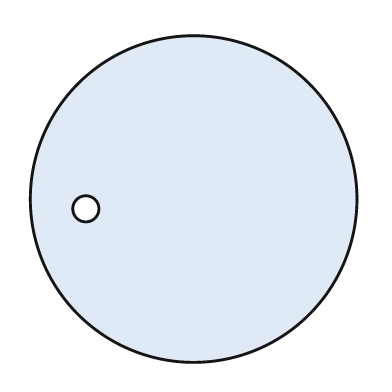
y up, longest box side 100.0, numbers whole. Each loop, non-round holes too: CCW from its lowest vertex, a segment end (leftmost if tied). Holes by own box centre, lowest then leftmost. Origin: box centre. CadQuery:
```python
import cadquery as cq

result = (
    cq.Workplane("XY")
    .moveTo(0.0, 0.0)
    .circle(50.0)
    .moveTo(-33.0, -3.0)
    .circle(4.0)
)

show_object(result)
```